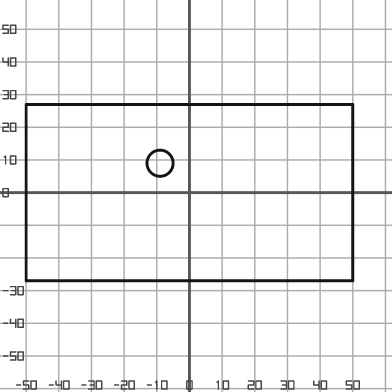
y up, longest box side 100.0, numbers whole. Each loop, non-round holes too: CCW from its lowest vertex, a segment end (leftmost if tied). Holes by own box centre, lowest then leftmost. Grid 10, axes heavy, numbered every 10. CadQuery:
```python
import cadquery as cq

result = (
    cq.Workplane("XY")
    .moveTo(-50.0, -27.0)
    .lineTo(50.0, -27.0)
    .lineTo(50.0, 27.0)
    .lineTo(-50.0, 27.0)
    .close()
    .moveTo(-9.0, 9.0)
    .circle(4.0)
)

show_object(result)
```